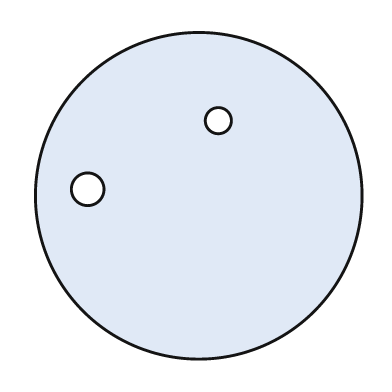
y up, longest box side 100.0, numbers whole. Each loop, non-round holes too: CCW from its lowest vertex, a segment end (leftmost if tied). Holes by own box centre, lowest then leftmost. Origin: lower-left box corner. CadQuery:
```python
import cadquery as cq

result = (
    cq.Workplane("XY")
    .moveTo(50.0, 50.0)
    .circle(50.0)
    .moveTo(16.0, 52.0)
    .circle(5.0)
    .moveTo(56.0, 73.0)
    .circle(4.0)
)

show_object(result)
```